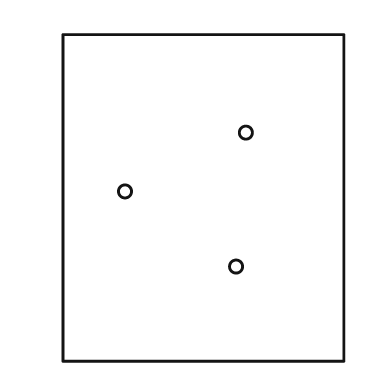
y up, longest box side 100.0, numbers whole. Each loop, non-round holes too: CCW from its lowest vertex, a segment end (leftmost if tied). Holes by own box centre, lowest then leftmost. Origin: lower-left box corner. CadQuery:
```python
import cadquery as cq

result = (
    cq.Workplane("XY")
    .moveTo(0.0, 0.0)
    .lineTo(86.0, 0.0)
    .lineTo(86.0, 100.0)
    .lineTo(0.0, 100.0)
    .close()
    .moveTo(53.0, 29.0)
    .circle(2.0)
    .moveTo(19.0, 52.0)
    .circle(2.0)
    .moveTo(56.0, 70.0)
    .circle(2.0)
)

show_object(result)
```